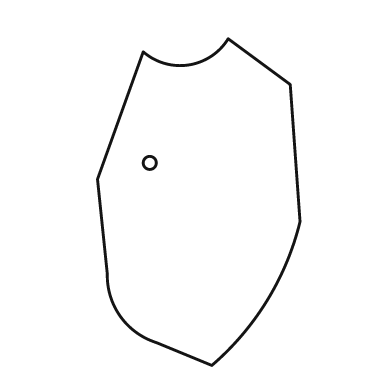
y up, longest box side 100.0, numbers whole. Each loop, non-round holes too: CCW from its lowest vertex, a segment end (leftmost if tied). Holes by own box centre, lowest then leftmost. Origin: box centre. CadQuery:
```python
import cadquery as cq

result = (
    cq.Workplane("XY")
    .moveTo(4.0, -50.0)
    .threePointArc((21.0, -30.0), (31.0, -6.0))
    .lineTo(28.0, 36.0)
    .lineTo(9.0, 50.0)
    .threePointArc((-3.0, 42.0), (-17.0, 46.0))
    .lineTo(-31.0, 7.0)
    .lineTo(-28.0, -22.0)
    .threePointArc((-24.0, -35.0), (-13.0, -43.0))
    .close()
    .moveTo(-15.0, 12.0)
    .circle(2.0)
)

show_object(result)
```